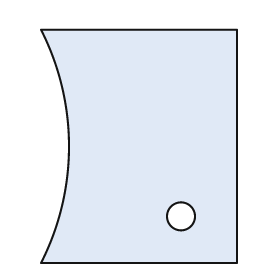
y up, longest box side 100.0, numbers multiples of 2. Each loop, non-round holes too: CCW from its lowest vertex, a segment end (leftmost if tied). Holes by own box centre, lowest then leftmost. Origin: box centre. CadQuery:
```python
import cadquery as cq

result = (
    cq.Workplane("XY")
    .moveTo(-42.0, -50.0)
    .lineTo(42.0, -50.0)
    .lineTo(42.0, 50.0)
    .lineTo(-42.0, 50.0)
    .threePointArc((-30.0, 0.0), (-42.0, -50.0))
    .close()
    .moveTo(18.0, -30.0)
    .circle(6.0)
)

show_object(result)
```